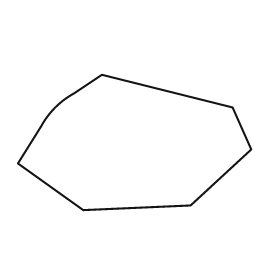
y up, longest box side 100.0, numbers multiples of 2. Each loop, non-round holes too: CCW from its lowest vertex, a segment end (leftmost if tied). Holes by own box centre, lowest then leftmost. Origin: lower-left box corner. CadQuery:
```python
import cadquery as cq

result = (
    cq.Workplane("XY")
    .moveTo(28.0, 0.0)
    .lineTo(74.0, 2.0)
    .lineTo(100.0, 26.0)
    .lineTo(92.0, 44.0)
    .lineTo(36.0, 58.0)
    .lineTo(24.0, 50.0)
    .threePointArc((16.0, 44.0), (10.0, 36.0))
    .lineTo(0.0, 20.0)
    .close()
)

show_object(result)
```